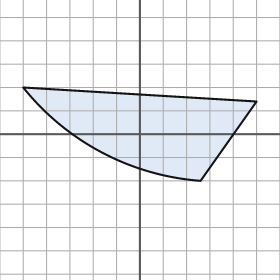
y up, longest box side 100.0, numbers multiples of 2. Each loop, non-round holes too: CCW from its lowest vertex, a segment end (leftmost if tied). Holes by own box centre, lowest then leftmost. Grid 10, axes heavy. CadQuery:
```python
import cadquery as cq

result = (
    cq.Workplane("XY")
    .moveTo(26.0, -20.0)
    .lineTo(50.0, 14.0)
    .lineTo(-50.0, 20.0)
    .threePointArc((-16.0, -8.0), (26.0, -20.0))
    .close()
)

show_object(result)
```